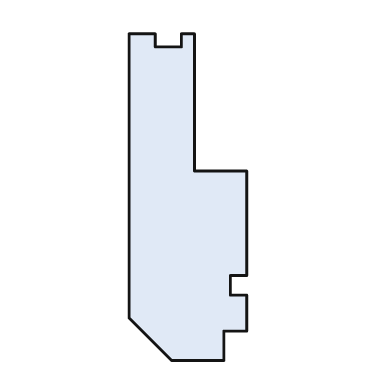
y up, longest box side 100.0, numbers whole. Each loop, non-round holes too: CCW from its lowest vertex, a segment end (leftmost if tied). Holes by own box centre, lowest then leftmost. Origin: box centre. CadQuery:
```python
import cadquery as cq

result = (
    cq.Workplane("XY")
    .moveTo(-5.0, -50.0)
    .lineTo(11.0, -50.0)
    .lineTo(11.0, -41.0)
    .lineTo(18.0, -41.0)
    .lineTo(18.0, -30.0)
    .lineTo(13.0, -30.0)
    .lineTo(13.0, -24.0)
    .lineTo(18.0, -24.0)
    .lineTo(18.0, 8.0)
    .lineTo(2.0, 8.0)
    .lineTo(2.0, 50.0)
    .lineTo(-2.0, 50.0)
    .lineTo(-2.0, 46.0)
    .lineTo(-10.0, 46.0)
    .lineTo(-10.0, 50.0)
    .lineTo(-18.0, 50.0)
    .lineTo(-18.0, -37.0)
    .close()
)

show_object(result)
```